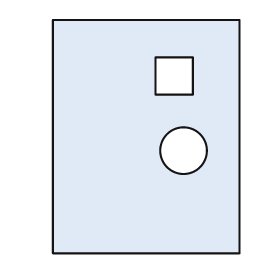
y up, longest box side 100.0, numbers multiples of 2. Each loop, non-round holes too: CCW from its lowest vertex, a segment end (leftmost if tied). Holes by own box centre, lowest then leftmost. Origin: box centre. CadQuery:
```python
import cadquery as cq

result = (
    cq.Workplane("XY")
    .moveTo(-40.0, -50.0)
    .lineTo(40.0, -50.0)
    .lineTo(40.0, 50.0)
    .lineTo(-40.0, 50.0)
    .close()
    .moveTo(16.0, -6.0)
    .circle(10.0)
    .moveTo(4.0, 18.0)
    .lineTo(20.0, 18.0)
    .lineTo(20.0, 34.0)
    .lineTo(4.0, 34.0)
    .close()
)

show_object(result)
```